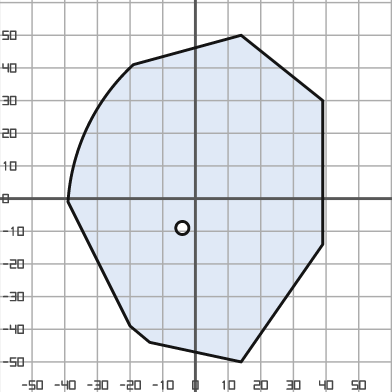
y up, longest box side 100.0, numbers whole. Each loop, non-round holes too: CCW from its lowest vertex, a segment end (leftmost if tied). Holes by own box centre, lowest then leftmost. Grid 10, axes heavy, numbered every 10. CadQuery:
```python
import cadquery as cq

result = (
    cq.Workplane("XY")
    .moveTo(14.0, -50.0)
    .lineTo(39.0, -14.0)
    .lineTo(39.0, 30.0)
    .lineTo(14.0, 50.0)
    .lineTo(-19.0, 41.0)
    .threePointArc((-33.0, 22.0), (-39.0, -1.0))
    .lineTo(-20.0, -39.0)
    .lineTo(-14.0, -44.0)
    .close()
    .moveTo(-4.0, -9.0)
    .circle(2.0)
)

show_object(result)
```